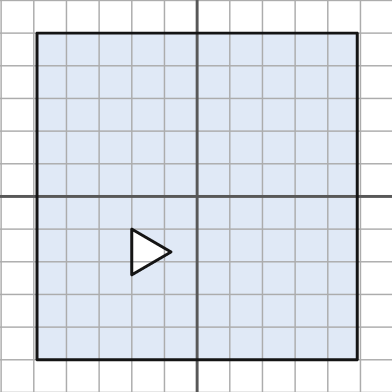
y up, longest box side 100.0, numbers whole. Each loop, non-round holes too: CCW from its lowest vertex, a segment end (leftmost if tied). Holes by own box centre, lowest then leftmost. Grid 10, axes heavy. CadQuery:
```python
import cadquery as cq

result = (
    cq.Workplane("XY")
    .moveTo(-49.0, -50.0)
    .lineTo(49.0, -50.0)
    .lineTo(49.0, 50.0)
    .lineTo(-49.0, 50.0)
    .close()
    .moveTo(-20.0, -24.0)
    .lineTo(-8.0, -17.0)
    .lineTo(-20.0, -10.0)
    .close()
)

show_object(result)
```